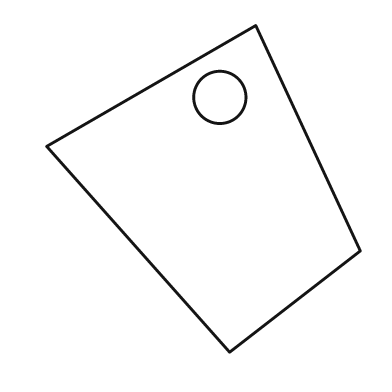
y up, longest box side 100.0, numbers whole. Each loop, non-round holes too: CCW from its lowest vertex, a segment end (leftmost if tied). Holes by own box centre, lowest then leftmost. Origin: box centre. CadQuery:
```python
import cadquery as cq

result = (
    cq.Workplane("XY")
    .moveTo(8.0, -50.0)
    .lineTo(48.0, -19.0)
    .lineTo(16.0, 50.0)
    .lineTo(-48.0, 13.0)
    .close()
    .moveTo(5.0, 28.0)
    .circle(8.0)
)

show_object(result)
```